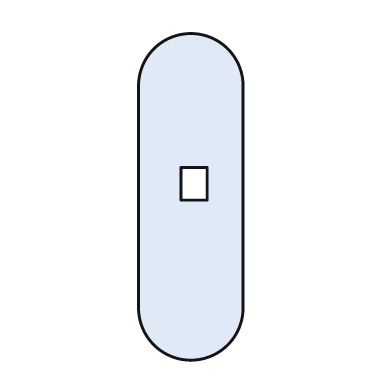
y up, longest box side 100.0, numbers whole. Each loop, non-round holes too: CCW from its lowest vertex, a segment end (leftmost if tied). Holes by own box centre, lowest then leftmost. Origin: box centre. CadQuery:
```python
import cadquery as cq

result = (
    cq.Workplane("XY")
    .moveTo(-16.0, -34.0)
    .threePointArc((0.0, -50.0), (16.0, -34.0))
    .lineTo(16.0, 34.0)
    .threePointArc((0.0, 50.0), (-16.0, 34.0))
    .close()
    .moveTo(-3.0, -1.0)
    .lineTo(5.0, -1.0)
    .lineTo(5.0, 9.0)
    .lineTo(-3.0, 9.0)
    .close()
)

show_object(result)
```